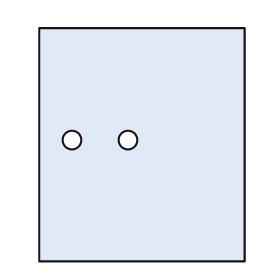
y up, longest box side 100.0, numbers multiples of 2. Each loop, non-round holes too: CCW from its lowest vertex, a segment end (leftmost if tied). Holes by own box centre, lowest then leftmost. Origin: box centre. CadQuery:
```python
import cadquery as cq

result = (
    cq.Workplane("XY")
    .moveTo(-44.0, -50.0)
    .lineTo(44.0, -50.0)
    .lineTo(44.0, 50.0)
    .lineTo(-44.0, 50.0)
    .close()
    .moveTo(-30.0, 2.0)
    .circle(4.0)
    .moveTo(-6.0, 2.0)
    .circle(4.0)
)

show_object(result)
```